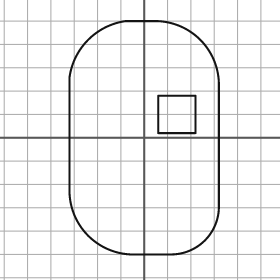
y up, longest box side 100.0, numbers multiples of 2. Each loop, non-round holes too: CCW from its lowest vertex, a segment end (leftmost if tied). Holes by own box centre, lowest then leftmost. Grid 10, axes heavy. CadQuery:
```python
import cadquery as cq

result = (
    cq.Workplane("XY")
    .moveTo(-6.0, -50.0)
    .lineTo(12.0, -50.0)
    .threePointArc((26.0, -44.0), (32.0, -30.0))
    .lineTo(32.0, 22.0)
    .threePointArc((24.0, 42.0), (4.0, 50.0))
    .lineTo(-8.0, 50.0)
    .threePointArc((-24.0, 42.0), (-32.0, 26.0))
    .lineTo(-32.0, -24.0)
    .threePointArc((-24.0, -42.0), (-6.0, -50.0))
    .close()
    .moveTo(6.0, 2.0)
    .lineTo(22.0, 2.0)
    .lineTo(22.0, 18.0)
    .lineTo(6.0, 18.0)
    .close()
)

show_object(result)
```